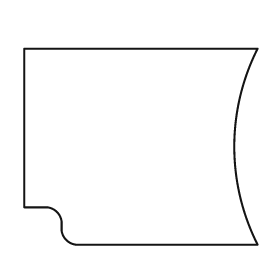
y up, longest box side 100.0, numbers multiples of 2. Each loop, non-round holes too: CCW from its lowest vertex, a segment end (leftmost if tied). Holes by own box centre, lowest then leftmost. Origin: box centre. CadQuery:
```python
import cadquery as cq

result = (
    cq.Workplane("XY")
    .moveTo(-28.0, -42.0)
    .lineTo(50.0, -42.0)
    .threePointArc((40.0, 0.0), (50.0, 42.0))
    .lineTo(-50.0, 42.0)
    .lineTo(-50.0, -26.0)
    .lineTo(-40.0, -26.0)
    .threePointArc((-36.0, -28.0), (-34.0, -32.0))
    .lineTo(-34.0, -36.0)
    .threePointArc((-32.0, -40.0), (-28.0, -42.0))
    .close()
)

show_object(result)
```